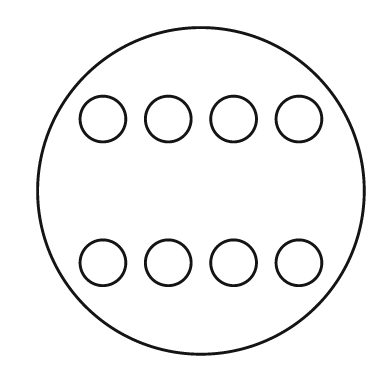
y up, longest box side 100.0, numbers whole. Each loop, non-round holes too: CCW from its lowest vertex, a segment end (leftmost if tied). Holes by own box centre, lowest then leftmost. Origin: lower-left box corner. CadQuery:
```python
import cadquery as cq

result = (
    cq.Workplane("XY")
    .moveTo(50.0, 50.0)
    .circle(50.0)
    .moveTo(20.0, 28.0)
    .circle(7.0)
    .moveTo(40.0, 28.0)
    .circle(7.0)
    .moveTo(60.0, 28.0)
    .circle(7.0)
    .moveTo(80.0, 28.0)
    .circle(7.0)
    .moveTo(20.0, 72.0)
    .circle(7.0)
    .moveTo(40.0, 72.0)
    .circle(7.0)
    .moveTo(60.0, 72.0)
    .circle(7.0)
    .moveTo(80.0, 72.0)
    .circle(7.0)
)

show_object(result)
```